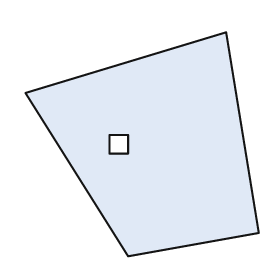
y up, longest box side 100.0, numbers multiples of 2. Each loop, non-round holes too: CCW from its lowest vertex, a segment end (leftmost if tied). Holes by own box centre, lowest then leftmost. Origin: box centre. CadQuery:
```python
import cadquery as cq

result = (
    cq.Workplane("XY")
    .moveTo(-6.0, -48.0)
    .lineTo(50.0, -38.0)
    .lineTo(36.0, 48.0)
    .lineTo(-50.0, 22.0)
    .close()
    .moveTo(-14.0, -4.0)
    .lineTo(-6.0, -4.0)
    .lineTo(-6.0, 4.0)
    .lineTo(-14.0, 4.0)
    .close()
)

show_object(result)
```